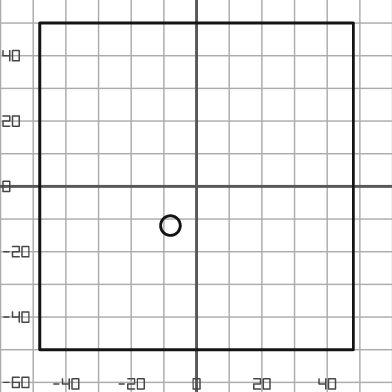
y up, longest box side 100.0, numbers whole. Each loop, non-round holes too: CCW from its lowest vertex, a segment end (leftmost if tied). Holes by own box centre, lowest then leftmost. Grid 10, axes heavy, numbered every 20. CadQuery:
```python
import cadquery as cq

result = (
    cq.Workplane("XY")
    .moveTo(-48.0, -50.0)
    .lineTo(48.0, -50.0)
    .lineTo(48.0, 50.0)
    .lineTo(-48.0, 50.0)
    .close()
    .moveTo(-8.0, -12.0)
    .circle(3.0)
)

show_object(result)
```